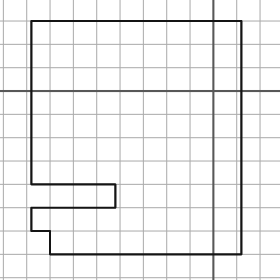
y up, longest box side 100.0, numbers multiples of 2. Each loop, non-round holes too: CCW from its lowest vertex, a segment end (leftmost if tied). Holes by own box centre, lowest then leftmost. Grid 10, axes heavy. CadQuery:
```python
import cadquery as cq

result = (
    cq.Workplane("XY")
    .moveTo(-70.0, -70.0)
    .lineTo(12.0, -70.0)
    .lineTo(12.0, 30.0)
    .lineTo(-78.0, 30.0)
    .lineTo(-78.0, -40.0)
    .lineTo(-42.0, -40.0)
    .lineTo(-42.0, -50.0)
    .lineTo(-78.0, -50.0)
    .lineTo(-78.0, -60.0)
    .lineTo(-70.0, -60.0)
    .close()
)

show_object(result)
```